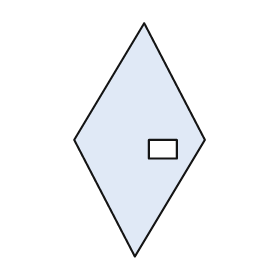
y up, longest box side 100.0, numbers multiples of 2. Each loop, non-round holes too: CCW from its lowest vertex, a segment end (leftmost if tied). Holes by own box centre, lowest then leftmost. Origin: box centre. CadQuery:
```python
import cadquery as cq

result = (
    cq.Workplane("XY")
    .moveTo(-2.0, -50.0)
    .lineTo(28.0, 0.0)
    .lineTo(2.0, 50.0)
    .lineTo(-28.0, 0.0)
    .close()
    .moveTo(4.0, -8.0)
    .lineTo(16.0, -8.0)
    .lineTo(16.0, 0.0)
    .lineTo(4.0, 0.0)
    .close()
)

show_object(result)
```